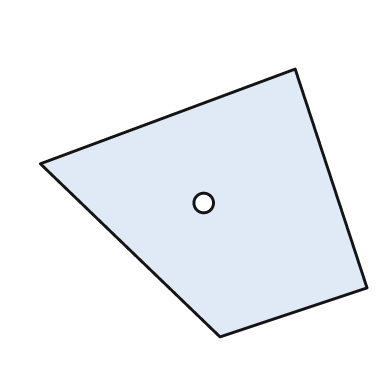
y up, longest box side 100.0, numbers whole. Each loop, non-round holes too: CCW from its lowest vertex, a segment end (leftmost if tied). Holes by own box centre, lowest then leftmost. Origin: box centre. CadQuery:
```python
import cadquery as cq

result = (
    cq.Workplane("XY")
    .moveTo(5.0, -41.0)
    .lineTo(50.0, -26.0)
    .lineTo(28.0, 41.0)
    .lineTo(-50.0, 12.0)
    .close()
    .moveTo(0.0, 0.0)
    .circle(3.0)
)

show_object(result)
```